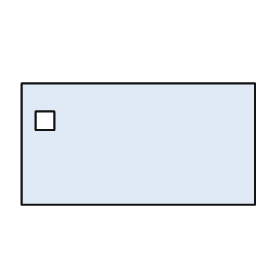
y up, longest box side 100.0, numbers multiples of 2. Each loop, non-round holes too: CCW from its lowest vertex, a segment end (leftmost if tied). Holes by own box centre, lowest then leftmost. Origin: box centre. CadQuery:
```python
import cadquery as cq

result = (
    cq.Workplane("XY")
    .moveTo(-50.0, -26.0)
    .lineTo(50.0, -26.0)
    .lineTo(50.0, 26.0)
    .lineTo(-50.0, 26.0)
    .close()
    .moveTo(-44.0, 6.0)
    .lineTo(-36.0, 6.0)
    .lineTo(-36.0, 14.0)
    .lineTo(-44.0, 14.0)
    .close()
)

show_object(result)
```